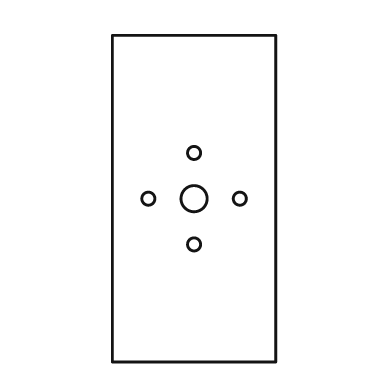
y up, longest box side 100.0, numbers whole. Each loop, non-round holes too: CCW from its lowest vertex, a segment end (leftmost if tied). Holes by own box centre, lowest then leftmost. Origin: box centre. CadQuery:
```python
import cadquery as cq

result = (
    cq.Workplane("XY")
    .moveTo(-25.0, -50.0)
    .lineTo(25.0, -50.0)
    .lineTo(25.0, 50.0)
    .lineTo(-25.0, 50.0)
    .close()
    .moveTo(0.0, -14.0)
    .circle(2.0)
    .moveTo(-14.0, 0.0)
    .circle(2.0)
    .moveTo(0.0, 0.0)
    .circle(4.0)
    .moveTo(14.0, 0.0)
    .circle(2.0)
    .moveTo(0.0, 14.0)
    .circle(2.0)
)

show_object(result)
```